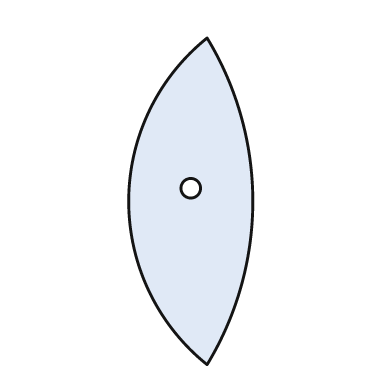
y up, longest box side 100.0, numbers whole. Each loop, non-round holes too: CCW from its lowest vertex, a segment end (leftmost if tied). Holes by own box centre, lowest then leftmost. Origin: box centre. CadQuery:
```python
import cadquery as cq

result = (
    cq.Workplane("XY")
    .moveTo(5.0, -50.0)
    .threePointArc((19.0, 0.0), (5.0, 50.0))
    .threePointArc((-19.0, 0.0), (5.0, -50.0))
    .close()
    .moveTo(0.0, 4.0)
    .circle(3.0)
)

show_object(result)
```